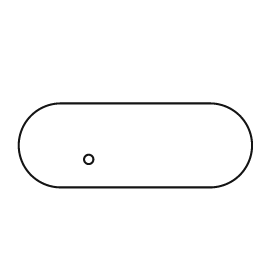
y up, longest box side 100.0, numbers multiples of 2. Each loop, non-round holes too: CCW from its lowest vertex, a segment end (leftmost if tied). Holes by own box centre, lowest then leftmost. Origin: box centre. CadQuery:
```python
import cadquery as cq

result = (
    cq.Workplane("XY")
    .moveTo(-32.0, -18.0)
    .lineTo(32.0, -18.0)
    .threePointArc((50.0, 0.0), (32.0, 18.0))
    .lineTo(-32.0, 18.0)
    .threePointArc((-50.0, 0.0), (-32.0, -18.0))
    .close()
    .moveTo(-20.0, -6.0)
    .circle(2.0)
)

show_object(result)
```